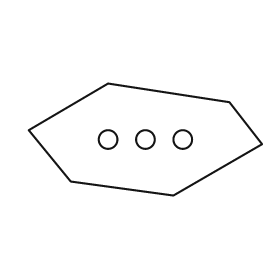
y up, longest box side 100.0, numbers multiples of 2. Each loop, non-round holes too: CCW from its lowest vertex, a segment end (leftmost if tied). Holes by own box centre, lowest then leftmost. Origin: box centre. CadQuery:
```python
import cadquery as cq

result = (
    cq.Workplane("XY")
    .moveTo(12.0, -24.0)
    .lineTo(50.0, -2.0)
    .lineTo(36.0, 16.0)
    .lineTo(-16.0, 24.0)
    .lineTo(-50.0, 4.0)
    .lineTo(-32.0, -18.0)
    .close()
    .moveTo(-16.0, 0.0)
    .circle(4.0)
    .moveTo(0.0, 0.0)
    .circle(4.0)
    .moveTo(16.0, 0.0)
    .circle(4.0)
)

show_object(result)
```